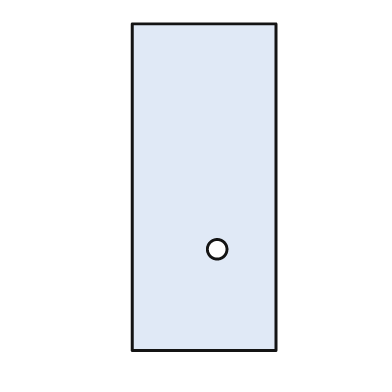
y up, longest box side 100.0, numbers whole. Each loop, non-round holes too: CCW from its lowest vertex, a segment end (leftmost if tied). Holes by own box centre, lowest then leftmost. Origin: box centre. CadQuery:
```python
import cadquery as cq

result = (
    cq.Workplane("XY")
    .moveTo(-22.0, -50.0)
    .lineTo(22.0, -50.0)
    .lineTo(22.0, 50.0)
    .lineTo(-22.0, 50.0)
    .close()
    .moveTo(4.0, -19.0)
    .circle(3.0)
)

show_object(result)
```